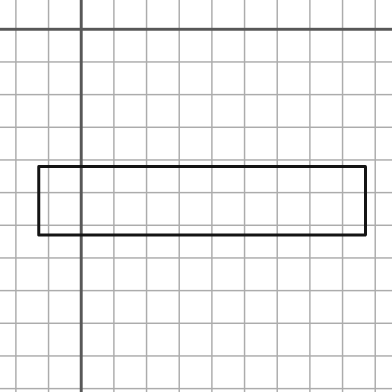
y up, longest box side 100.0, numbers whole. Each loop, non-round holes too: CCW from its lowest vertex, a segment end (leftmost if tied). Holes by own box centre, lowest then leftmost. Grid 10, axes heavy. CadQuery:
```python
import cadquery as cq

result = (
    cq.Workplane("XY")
    .moveTo(-13.0, -63.0)
    .lineTo(87.0, -63.0)
    .lineTo(87.0, -42.0)
    .lineTo(-13.0, -42.0)
    .close()
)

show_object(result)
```